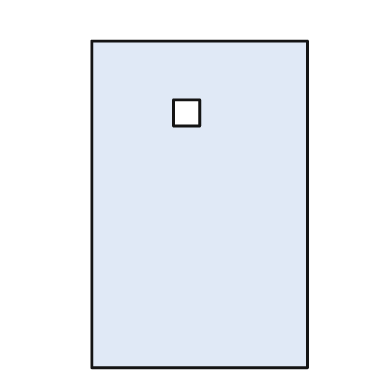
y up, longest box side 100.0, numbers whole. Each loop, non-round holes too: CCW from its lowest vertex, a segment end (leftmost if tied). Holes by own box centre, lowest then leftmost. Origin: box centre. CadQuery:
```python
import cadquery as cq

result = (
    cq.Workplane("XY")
    .moveTo(-33.0, -50.0)
    .lineTo(33.0, -50.0)
    .lineTo(33.0, 50.0)
    .lineTo(-33.0, 50.0)
    .close()
    .moveTo(-8.0, 24.0)
    .lineTo(0.0, 24.0)
    .lineTo(0.0, 32.0)
    .lineTo(-8.0, 32.0)
    .close()
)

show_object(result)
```